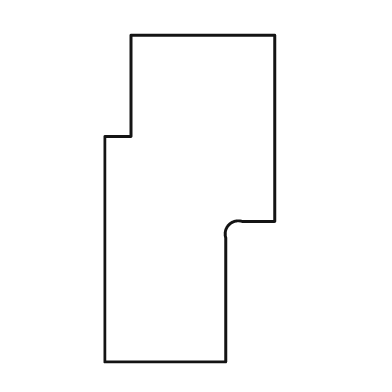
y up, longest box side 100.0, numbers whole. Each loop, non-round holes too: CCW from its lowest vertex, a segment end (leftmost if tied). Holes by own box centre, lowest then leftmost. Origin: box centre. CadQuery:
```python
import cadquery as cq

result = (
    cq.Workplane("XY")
    .moveTo(-26.0, -50.0)
    .lineTo(11.0, -50.0)
    .lineTo(11.0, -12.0)
    .threePointArc((12.0, -8.0), (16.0, -7.0))
    .lineTo(26.0, -7.0)
    .lineTo(26.0, 50.0)
    .lineTo(-18.0, 50.0)
    .lineTo(-18.0, 19.0)
    .lineTo(-26.0, 19.0)
    .close()
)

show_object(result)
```